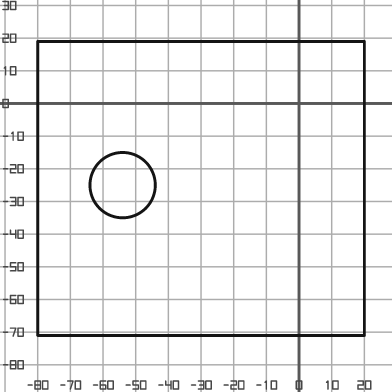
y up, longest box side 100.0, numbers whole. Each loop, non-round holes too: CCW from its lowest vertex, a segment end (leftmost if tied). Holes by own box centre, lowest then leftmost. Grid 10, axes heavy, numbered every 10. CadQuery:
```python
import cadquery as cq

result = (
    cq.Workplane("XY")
    .moveTo(-80.0, -71.0)
    .lineTo(20.0, -71.0)
    .lineTo(20.0, 19.0)
    .lineTo(-80.0, 19.0)
    .close()
    .moveTo(-54.0, -25.0)
    .circle(10.0)
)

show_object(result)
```